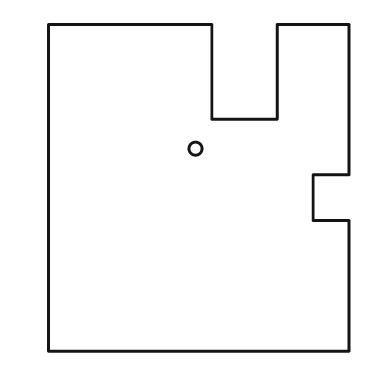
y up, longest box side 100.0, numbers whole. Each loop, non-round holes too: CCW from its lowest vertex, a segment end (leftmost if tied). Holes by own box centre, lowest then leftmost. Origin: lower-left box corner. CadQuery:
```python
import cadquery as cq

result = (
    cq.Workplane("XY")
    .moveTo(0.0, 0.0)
    .lineTo(92.0, 0.0)
    .lineTo(92.0, 40.0)
    .lineTo(81.0, 40.0)
    .lineTo(81.0, 54.0)
    .lineTo(92.0, 54.0)
    .lineTo(92.0, 100.0)
    .lineTo(70.0, 100.0)
    .lineTo(70.0, 71.0)
    .lineTo(50.0, 71.0)
    .lineTo(50.0, 100.0)
    .lineTo(0.0, 100.0)
    .close()
    .moveTo(45.0, 62.0)
    .circle(2.0)
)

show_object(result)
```